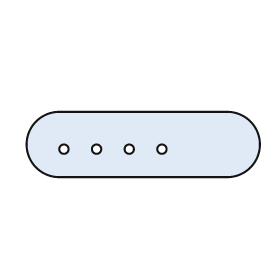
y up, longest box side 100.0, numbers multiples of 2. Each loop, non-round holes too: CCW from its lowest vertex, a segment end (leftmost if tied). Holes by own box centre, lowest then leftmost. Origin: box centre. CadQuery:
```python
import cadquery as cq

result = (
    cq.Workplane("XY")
    .moveTo(-36.0, -14.0)
    .lineTo(36.0, -14.0)
    .threePointArc((50.0, 0.0), (36.0, 14.0))
    .lineTo(-36.0, 14.0)
    .threePointArc((-50.0, 0.0), (-36.0, -14.0))
    .close()
    .moveTo(-34.0, -2.0)
    .circle(2.0)
    .moveTo(-20.0, -2.0)
    .circle(2.0)
    .moveTo(-6.0, -2.0)
    .circle(2.0)
    .moveTo(8.0, -2.0)
    .circle(2.0)
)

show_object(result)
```